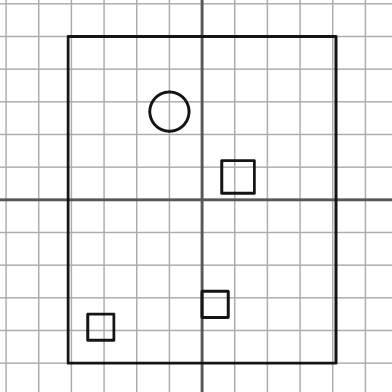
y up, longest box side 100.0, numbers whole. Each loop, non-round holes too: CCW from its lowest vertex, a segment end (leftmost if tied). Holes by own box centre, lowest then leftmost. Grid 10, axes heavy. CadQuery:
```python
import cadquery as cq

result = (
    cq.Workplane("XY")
    .moveTo(-41.0, -50.0)
    .lineTo(41.0, -50.0)
    .lineTo(41.0, 50.0)
    .lineTo(-41.0, 50.0)
    .close()
    .moveTo(-35.0, -43.0)
    .lineTo(-27.0, -43.0)
    .lineTo(-27.0, -35.0)
    .lineTo(-35.0, -35.0)
    .close()
    .moveTo(0.0, -36.0)
    .lineTo(8.0, -36.0)
    .lineTo(8.0, -28.0)
    .lineTo(0.0, -28.0)
    .close()
    .moveTo(6.0, 2.0)
    .lineTo(16.0, 2.0)
    .lineTo(16.0, 12.0)
    .lineTo(6.0, 12.0)
    .close()
    .moveTo(-10.0, 27.0)
    .circle(6.0)
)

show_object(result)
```